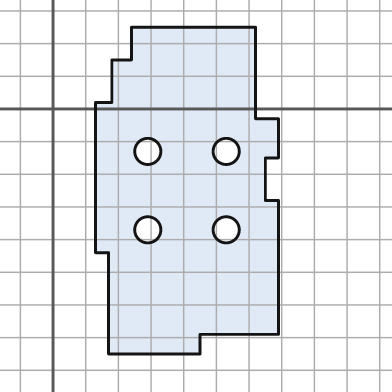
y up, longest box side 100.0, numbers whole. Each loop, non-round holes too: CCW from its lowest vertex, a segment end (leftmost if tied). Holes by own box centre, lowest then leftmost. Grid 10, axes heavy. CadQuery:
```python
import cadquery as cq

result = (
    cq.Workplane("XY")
    .moveTo(17.0, -75.0)
    .lineTo(45.0, -75.0)
    .lineTo(45.0, -69.0)
    .lineTo(69.0, -69.0)
    .lineTo(69.0, -28.0)
    .lineTo(65.0, -28.0)
    .lineTo(65.0, -15.0)
    .lineTo(69.0, -15.0)
    .lineTo(69.0, -3.0)
    .lineTo(62.0, -3.0)
    .lineTo(62.0, 25.0)
    .lineTo(24.0, 25.0)
    .lineTo(24.0, 15.0)
    .lineTo(18.0, 15.0)
    .lineTo(18.0, 2.0)
    .lineTo(13.0, 2.0)
    .lineTo(13.0, -44.0)
    .lineTo(17.0, -44.0)
    .close()
    .moveTo(29.0, -37.0)
    .circle(4.0)
    .moveTo(53.0, -37.0)
    .circle(4.0)
    .moveTo(29.0, -13.0)
    .circle(4.0)
    .moveTo(53.0, -13.0)
    .circle(4.0)
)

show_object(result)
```